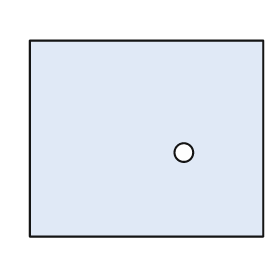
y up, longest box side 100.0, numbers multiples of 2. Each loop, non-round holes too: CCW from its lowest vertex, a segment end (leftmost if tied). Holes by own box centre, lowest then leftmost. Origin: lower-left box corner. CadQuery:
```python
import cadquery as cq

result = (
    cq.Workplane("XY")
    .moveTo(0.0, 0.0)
    .lineTo(100.0, 0.0)
    .lineTo(100.0, 84.0)
    .lineTo(0.0, 84.0)
    .close()
    .moveTo(66.0, 36.0)
    .circle(4.0)
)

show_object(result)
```